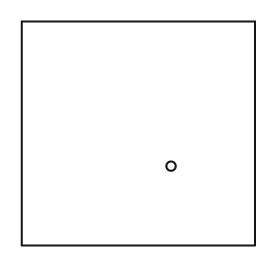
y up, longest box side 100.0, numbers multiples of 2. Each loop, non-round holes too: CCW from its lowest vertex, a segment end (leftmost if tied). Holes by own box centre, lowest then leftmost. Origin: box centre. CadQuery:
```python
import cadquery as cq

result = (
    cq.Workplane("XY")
    .moveTo(-50.0, -48.0)
    .lineTo(50.0, -48.0)
    .lineTo(50.0, 48.0)
    .lineTo(-50.0, 48.0)
    .close()
    .moveTo(14.0, -14.0)
    .circle(2.0)
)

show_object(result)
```